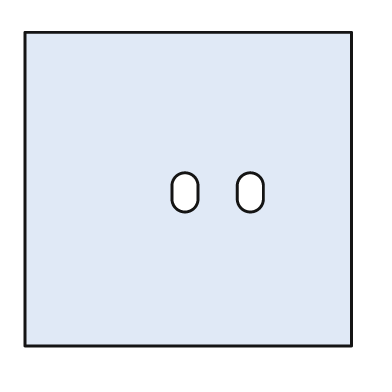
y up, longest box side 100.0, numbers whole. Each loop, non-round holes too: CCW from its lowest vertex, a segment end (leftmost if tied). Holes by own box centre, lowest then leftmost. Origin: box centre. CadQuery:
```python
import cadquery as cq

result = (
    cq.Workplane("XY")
    .moveTo(-50.0, -48.0)
    .lineTo(50.0, -48.0)
    .lineTo(50.0, 48.0)
    .lineTo(-50.0, 48.0)
    .close()
    .moveTo(-5.0, -3.0)
    .threePointArc((-1.0, -7.0), (3.0, -3.0))
    .lineTo(3.0, 1.0)
    .threePointArc((-1.0, 5.0), (-5.0, 1.0))
    .close()
    .moveTo(15.0, -3.0)
    .threePointArc((19.0, -7.0), (23.0, -3.0))
    .lineTo(23.0, 1.0)
    .threePointArc((19.0, 5.0), (15.0, 1.0))
    .close()
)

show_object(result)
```